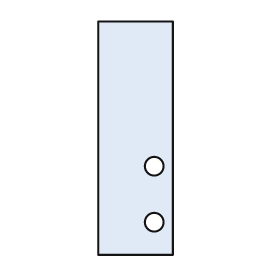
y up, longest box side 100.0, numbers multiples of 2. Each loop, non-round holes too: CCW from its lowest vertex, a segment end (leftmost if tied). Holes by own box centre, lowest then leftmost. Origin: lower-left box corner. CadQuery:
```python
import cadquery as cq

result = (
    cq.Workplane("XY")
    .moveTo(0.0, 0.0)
    .lineTo(32.0, 0.0)
    .lineTo(32.0, 100.0)
    .lineTo(0.0, 100.0)
    .close()
    .moveTo(24.0, 14.0)
    .circle(4.0)
    .moveTo(24.0, 38.0)
    .circle(4.0)
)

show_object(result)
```